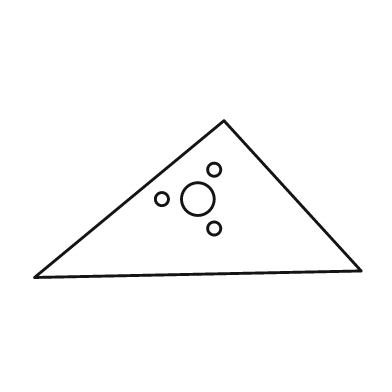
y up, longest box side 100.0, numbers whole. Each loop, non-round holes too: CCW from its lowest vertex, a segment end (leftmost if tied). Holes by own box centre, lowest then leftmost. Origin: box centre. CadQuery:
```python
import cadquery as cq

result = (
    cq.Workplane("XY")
    .moveTo(-50.0, -24.0)
    .lineTo(50.0, -22.0)
    .lineTo(8.0, 24.0)
    .close()
    .moveTo(5.0, -9.0)
    .circle(2.0)
    .moveTo(-11.0, 0.0)
    .circle(2.0)
    .moveTo(0.0, 0.0)
    .circle(5.0)
    .moveTo(5.0, 9.0)
    .circle(2.0)
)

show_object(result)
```